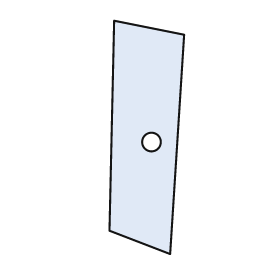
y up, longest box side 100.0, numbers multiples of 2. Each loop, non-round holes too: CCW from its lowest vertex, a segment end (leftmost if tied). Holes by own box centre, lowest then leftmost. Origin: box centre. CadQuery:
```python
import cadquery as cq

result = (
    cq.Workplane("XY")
    .moveTo(10.0, -50.0)
    .lineTo(16.0, 44.0)
    .lineTo(-14.0, 50.0)
    .lineTo(-16.0, -40.0)
    .close()
    .moveTo(2.0, -2.0)
    .circle(4.0)
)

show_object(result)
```